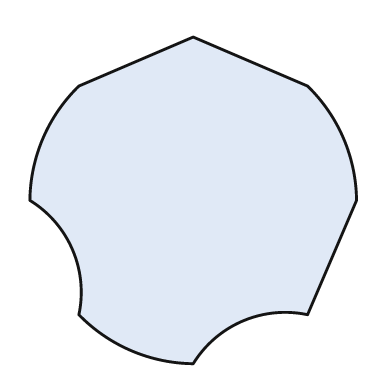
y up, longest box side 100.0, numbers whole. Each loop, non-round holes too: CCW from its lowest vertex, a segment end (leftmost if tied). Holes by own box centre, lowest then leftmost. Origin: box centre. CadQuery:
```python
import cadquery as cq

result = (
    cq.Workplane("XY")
    .moveTo(0.0, -50.0)
    .threePointArc((15.0, -37.0), (35.0, -35.0))
    .lineTo(50.0, 0.0)
    .threePointArc((46.0, 19.0), (35.0, 35.0))
    .lineTo(0.0, 50.0)
    .lineTo(-35.0, 35.0)
    .threePointArc((-46.0, 19.0), (-50.0, 0.0))
    .threePointArc((-37.0, -15.0), (-35.0, -35.0))
    .threePointArc((-19.0, -46.0), (0.0, -50.0))
    .close()
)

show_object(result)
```